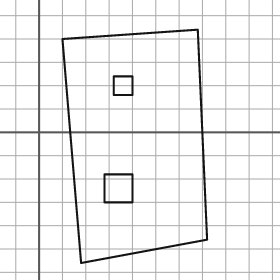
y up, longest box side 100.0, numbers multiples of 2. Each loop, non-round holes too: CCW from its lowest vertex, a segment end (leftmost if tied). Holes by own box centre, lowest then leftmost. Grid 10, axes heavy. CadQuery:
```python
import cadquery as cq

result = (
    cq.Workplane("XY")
    .moveTo(18.0, -56.0)
    .lineTo(72.0, -46.0)
    .lineTo(68.0, 44.0)
    .lineTo(10.0, 40.0)
    .close()
    .moveTo(28.0, -30.0)
    .lineTo(40.0, -30.0)
    .lineTo(40.0, -18.0)
    .lineTo(28.0, -18.0)
    .close()
    .moveTo(32.0, 16.0)
    .lineTo(40.0, 16.0)
    .lineTo(40.0, 24.0)
    .lineTo(32.0, 24.0)
    .close()
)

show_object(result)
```